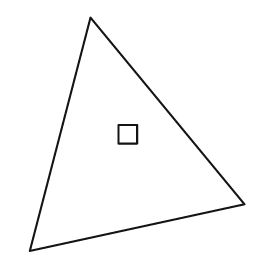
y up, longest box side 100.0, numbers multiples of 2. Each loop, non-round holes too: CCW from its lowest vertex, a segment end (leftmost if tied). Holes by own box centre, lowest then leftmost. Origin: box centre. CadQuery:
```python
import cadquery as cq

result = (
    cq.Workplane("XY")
    .moveTo(-46.0, -50.0)
    .lineTo(46.0, -30.0)
    .lineTo(-20.0, 50.0)
    .close()
    .moveTo(-8.0, -4.0)
    .lineTo(0.0, -4.0)
    .lineTo(0.0, 4.0)
    .lineTo(-8.0, 4.0)
    .close()
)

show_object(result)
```